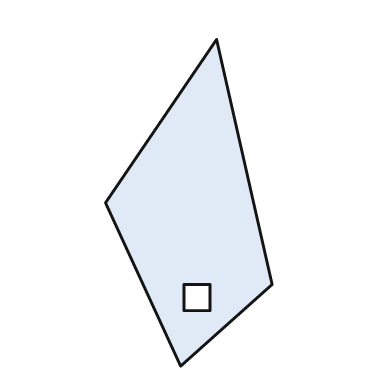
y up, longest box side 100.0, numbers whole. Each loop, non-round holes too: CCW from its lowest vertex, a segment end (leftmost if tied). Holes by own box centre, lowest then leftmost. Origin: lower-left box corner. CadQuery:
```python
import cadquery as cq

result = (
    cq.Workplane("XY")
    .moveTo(23.0, 0.0)
    .lineTo(51.0, 25.0)
    .lineTo(34.0, 100.0)
    .lineTo(0.0, 50.0)
    .close()
    .moveTo(24.0, 17.0)
    .lineTo(32.0, 17.0)
    .lineTo(32.0, 25.0)
    .lineTo(24.0, 25.0)
    .close()
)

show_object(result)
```